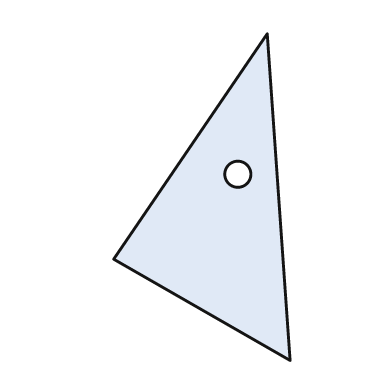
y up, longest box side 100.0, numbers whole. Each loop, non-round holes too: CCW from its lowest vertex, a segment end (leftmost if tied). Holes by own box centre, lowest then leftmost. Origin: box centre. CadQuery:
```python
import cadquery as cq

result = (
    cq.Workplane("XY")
    .moveTo(27.0, -50.0)
    .lineTo(20.0, 50.0)
    .lineTo(-27.0, -19.0)
    .close()
    .moveTo(11.0, 7.0)
    .circle(4.0)
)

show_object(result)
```